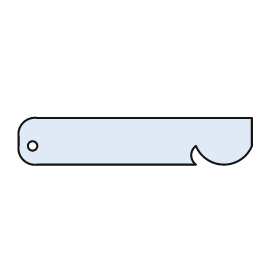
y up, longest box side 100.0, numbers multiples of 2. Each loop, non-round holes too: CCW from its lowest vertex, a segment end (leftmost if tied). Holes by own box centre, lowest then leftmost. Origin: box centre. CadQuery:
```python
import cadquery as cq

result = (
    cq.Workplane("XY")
    .moveTo(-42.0, -10.0)
    .lineTo(26.0, -10.0)
    .threePointArc((24.0, -6.0), (26.0, -2.0))
    .threePointArc((38.0, -10.0), (50.0, -2.0))
    .lineTo(50.0, 10.0)
    .lineTo(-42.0, 10.0)
    .threePointArc((-48.0, 8.0), (-50.0, 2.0))
    .lineTo(-50.0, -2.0)
    .threePointArc((-48.0, -8.0), (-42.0, -10.0))
    .close()
    .moveTo(-44.0, -2.0)
    .circle(2.0)
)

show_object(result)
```